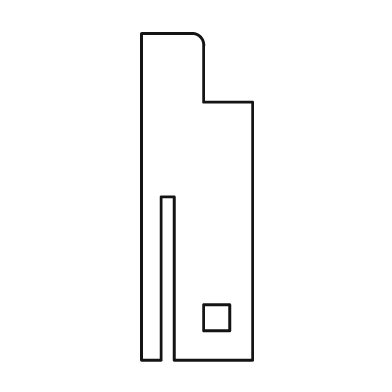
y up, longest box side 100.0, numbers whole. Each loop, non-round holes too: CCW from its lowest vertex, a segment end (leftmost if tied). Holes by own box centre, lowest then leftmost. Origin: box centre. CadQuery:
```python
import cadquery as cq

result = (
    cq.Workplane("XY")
    .moveTo(-17.0, -50.0)
    .lineTo(-11.0, -50.0)
    .lineTo(-11.0, 0.0)
    .lineTo(-7.0, 0.0)
    .lineTo(-7.0, -50.0)
    .lineTo(17.0, -50.0)
    .lineTo(17.0, 29.0)
    .lineTo(2.0, 29.0)
    .lineTo(2.0, 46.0)
    .threePointArc((1.0, 49.0), (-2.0, 50.0))
    .lineTo(-17.0, 50.0)
    .close()
    .moveTo(2.0, -41.0)
    .lineTo(10.0, -41.0)
    .lineTo(10.0, -33.0)
    .lineTo(2.0, -33.0)
    .close()
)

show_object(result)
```